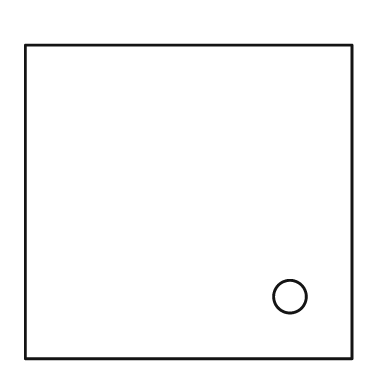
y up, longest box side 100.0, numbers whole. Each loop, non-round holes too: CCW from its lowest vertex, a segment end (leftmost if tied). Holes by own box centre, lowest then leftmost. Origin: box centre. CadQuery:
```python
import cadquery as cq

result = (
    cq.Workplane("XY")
    .moveTo(-50.0, -48.0)
    .lineTo(50.0, -48.0)
    .lineTo(50.0, 48.0)
    .lineTo(-50.0, 48.0)
    .close()
    .moveTo(31.0, -29.0)
    .circle(5.0)
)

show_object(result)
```